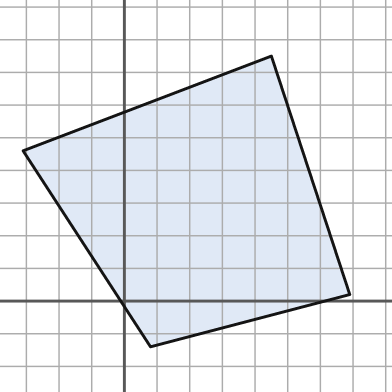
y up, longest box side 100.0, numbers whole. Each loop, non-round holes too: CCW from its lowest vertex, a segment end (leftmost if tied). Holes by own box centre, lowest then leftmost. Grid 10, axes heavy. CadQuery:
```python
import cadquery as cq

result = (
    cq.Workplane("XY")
    .moveTo(8.0, -14.0)
    .lineTo(69.0, 2.0)
    .lineTo(45.0, 75.0)
    .lineTo(-31.0, 46.0)
    .close()
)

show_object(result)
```